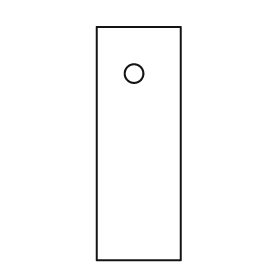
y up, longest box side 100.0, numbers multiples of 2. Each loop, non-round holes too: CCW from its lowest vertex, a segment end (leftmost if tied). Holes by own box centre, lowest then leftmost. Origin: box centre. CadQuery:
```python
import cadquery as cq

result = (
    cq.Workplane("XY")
    .moveTo(-18.0, -50.0)
    .lineTo(18.0, -50.0)
    .lineTo(18.0, 50.0)
    .lineTo(-18.0, 50.0)
    .close()
    .moveTo(-2.0, 30.0)
    .circle(4.0)
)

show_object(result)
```